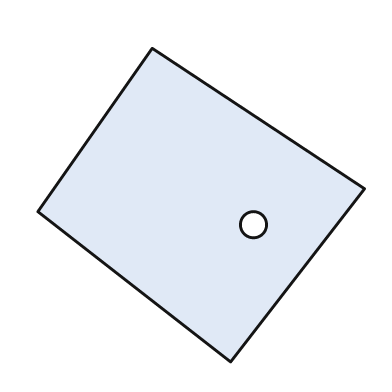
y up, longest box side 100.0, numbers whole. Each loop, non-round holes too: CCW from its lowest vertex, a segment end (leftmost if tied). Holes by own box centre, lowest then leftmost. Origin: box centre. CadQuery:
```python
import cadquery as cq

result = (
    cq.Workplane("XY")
    .moveTo(9.0, -48.0)
    .lineTo(50.0, 5.0)
    .lineTo(-15.0, 48.0)
    .lineTo(-50.0, -2.0)
    .close()
    .moveTo(16.0, -6.0)
    .circle(4.0)
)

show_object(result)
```